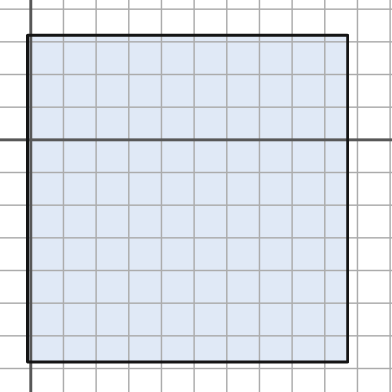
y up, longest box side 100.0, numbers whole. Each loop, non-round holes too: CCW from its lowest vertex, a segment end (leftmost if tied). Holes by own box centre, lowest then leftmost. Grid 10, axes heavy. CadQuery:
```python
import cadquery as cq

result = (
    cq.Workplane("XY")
    .moveTo(-1.0, -68.0)
    .lineTo(97.0, -68.0)
    .lineTo(97.0, 32.0)
    .lineTo(-1.0, 32.0)
    .close()
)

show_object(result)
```